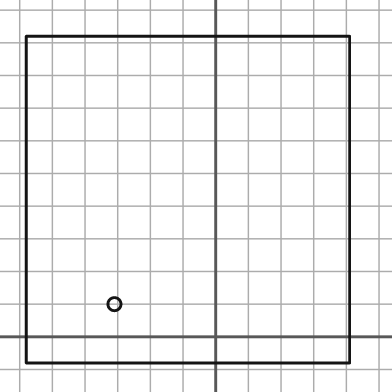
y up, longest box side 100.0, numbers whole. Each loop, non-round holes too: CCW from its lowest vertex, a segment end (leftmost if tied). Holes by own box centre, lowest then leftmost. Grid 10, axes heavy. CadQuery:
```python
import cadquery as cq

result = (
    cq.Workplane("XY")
    .moveTo(-58.0, -8.0)
    .lineTo(41.0, -8.0)
    .lineTo(41.0, 92.0)
    .lineTo(-58.0, 92.0)
    .close()
    .moveTo(-31.0, 10.0)
    .circle(2.0)
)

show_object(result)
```